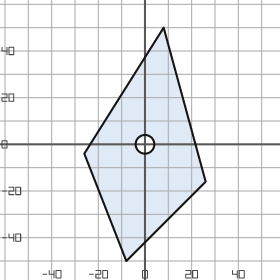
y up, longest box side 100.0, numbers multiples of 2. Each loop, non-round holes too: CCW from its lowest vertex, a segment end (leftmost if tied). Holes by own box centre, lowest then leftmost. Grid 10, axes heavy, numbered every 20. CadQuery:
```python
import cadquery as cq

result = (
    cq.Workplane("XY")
    .moveTo(-8.0, -50.0)
    .lineTo(26.0, -16.0)
    .lineTo(8.0, 50.0)
    .lineTo(-26.0, -4.0)
    .close()
    .moveTo(0.0, 0.0)
    .circle(4.0)
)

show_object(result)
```